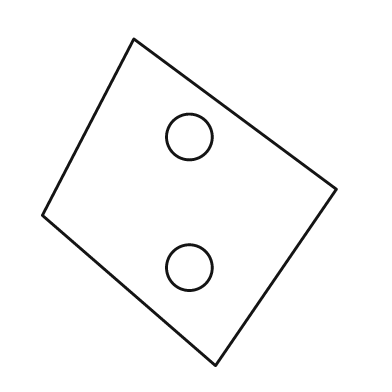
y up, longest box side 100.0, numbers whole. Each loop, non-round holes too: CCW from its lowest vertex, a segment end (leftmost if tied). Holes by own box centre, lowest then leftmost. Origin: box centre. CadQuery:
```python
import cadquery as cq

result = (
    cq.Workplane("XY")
    .moveTo(8.0, -50.0)
    .lineTo(45.0, 4.0)
    .lineTo(-17.0, 50.0)
    .lineTo(-45.0, -4.0)
    .close()
    .moveTo(0.0, -20.0)
    .circle(7.0)
    .moveTo(0.0, 20.0)
    .circle(7.0)
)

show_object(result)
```